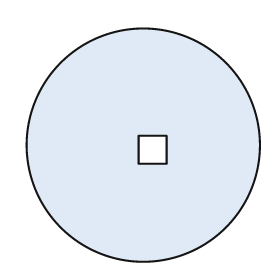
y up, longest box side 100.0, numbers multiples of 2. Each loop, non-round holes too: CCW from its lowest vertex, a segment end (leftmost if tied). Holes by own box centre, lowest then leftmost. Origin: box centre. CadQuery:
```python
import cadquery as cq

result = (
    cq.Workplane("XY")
    .moveTo(0.0, 0.0)
    .circle(50.0)
    .moveTo(-2.0, -8.0)
    .lineTo(10.0, -8.0)
    .lineTo(10.0, 4.0)
    .lineTo(-2.0, 4.0)
    .close()
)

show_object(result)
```